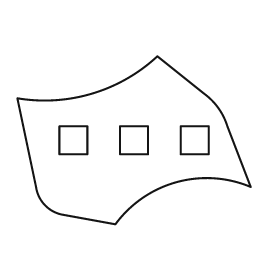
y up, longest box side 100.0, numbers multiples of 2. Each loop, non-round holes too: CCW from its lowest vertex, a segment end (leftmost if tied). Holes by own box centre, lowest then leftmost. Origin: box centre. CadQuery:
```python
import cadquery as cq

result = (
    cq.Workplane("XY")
    .moveTo(-8.0, -36.0)
    .threePointArc((18.0, -18.0), (50.0, -20.0))
    .lineTo(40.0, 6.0)
    .threePointArc((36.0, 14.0), (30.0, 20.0))
    .lineTo(10.0, 36.0)
    .threePointArc((-18.0, 20.0), (-50.0, 18.0))
    .lineTo(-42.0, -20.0)
    .threePointArc((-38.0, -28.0), (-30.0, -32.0))
    .close()
    .moveTo(-32.0, -6.0)
    .lineTo(-20.0, -6.0)
    .lineTo(-20.0, 6.0)
    .lineTo(-32.0, 6.0)
    .close()
    .moveTo(-6.0, -6.0)
    .lineTo(6.0, -6.0)
    .lineTo(6.0, 6.0)
    .lineTo(-6.0, 6.0)
    .close()
    .moveTo(20.0, -6.0)
    .lineTo(32.0, -6.0)
    .lineTo(32.0, 6.0)
    .lineTo(20.0, 6.0)
    .close()
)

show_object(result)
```